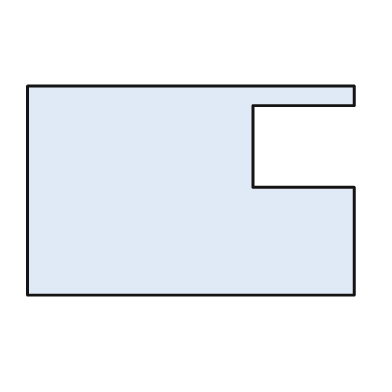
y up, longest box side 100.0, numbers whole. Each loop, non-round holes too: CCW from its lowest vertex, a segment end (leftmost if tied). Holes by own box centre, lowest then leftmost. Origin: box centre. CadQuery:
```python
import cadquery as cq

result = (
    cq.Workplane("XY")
    .moveTo(-50.0, -32.0)
    .lineTo(50.0, -32.0)
    .lineTo(50.0, 1.0)
    .lineTo(19.0, 1.0)
    .lineTo(19.0, 26.0)
    .lineTo(50.0, 26.0)
    .lineTo(50.0, 32.0)
    .lineTo(-50.0, 32.0)
    .close()
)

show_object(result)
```